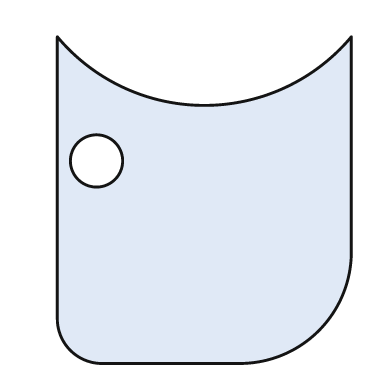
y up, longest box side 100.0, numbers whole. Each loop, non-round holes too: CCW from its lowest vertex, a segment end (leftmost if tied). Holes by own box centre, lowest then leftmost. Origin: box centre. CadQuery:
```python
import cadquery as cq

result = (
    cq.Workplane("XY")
    .moveTo(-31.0, -50.0)
    .lineTo(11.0, -50.0)
    .threePointArc((35.0, -40.0), (45.0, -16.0))
    .lineTo(45.0, 50.0)
    .threePointArc((0.0, 29.0), (-45.0, 50.0))
    .lineTo(-45.0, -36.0)
    .threePointArc((-41.0, -46.0), (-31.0, -50.0))
    .close()
    .moveTo(-33.0, 12.0)
    .circle(8.0)
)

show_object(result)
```